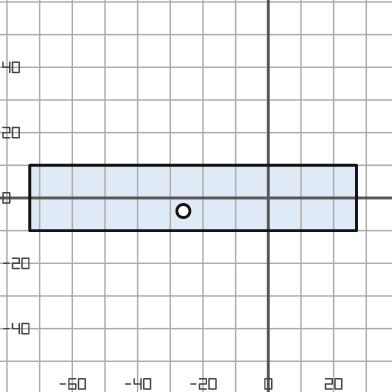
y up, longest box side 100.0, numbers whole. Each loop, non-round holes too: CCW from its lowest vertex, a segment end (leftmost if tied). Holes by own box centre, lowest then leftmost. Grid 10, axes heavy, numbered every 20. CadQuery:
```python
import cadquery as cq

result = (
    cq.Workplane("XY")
    .moveTo(-73.0, -10.0)
    .lineTo(27.0, -10.0)
    .lineTo(27.0, 10.0)
    .lineTo(-73.0, 10.0)
    .close()
    .moveTo(-26.0, -4.0)
    .circle(2.0)
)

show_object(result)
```